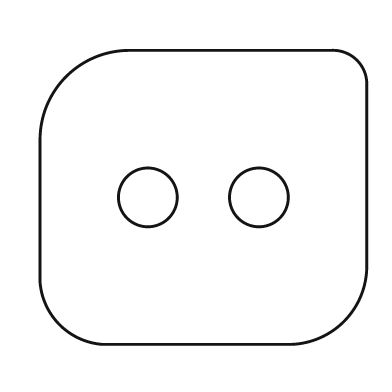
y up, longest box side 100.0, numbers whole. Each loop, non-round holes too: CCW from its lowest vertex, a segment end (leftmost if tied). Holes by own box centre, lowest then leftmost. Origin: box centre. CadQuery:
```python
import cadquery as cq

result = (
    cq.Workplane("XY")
    .moveTo(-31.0, -45.0)
    .lineTo(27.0, -45.0)
    .threePointArc((43.0, -38.0), (50.0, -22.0))
    .lineTo(50.0, 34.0)
    .threePointArc((47.0, 42.0), (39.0, 45.0))
    .lineTo(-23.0, 45.0)
    .threePointArc((-42.0, 37.0), (-50.0, 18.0))
    .lineTo(-50.0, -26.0)
    .threePointArc((-44.0, -39.0), (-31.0, -45.0))
    .close()
    .moveTo(-17.0, 0.0)
    .circle(9.0)
    .moveTo(17.0, 0.0)
    .circle(9.0)
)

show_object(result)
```